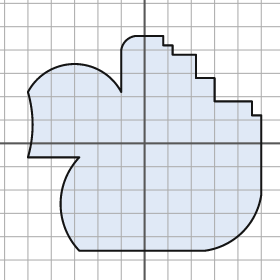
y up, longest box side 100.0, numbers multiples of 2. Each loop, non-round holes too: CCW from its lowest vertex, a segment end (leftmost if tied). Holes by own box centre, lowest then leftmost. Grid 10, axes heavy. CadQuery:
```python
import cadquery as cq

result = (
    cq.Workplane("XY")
    .moveTo(-28.0, -46.0)
    .lineTo(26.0, -46.0)
    .threePointArc((42.0, -38.0), (50.0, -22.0))
    .lineTo(50.0, 12.0)
    .lineTo(46.0, 12.0)
    .lineTo(46.0, 18.0)
    .lineTo(30.0, 18.0)
    .lineTo(30.0, 28.0)
    .lineTo(22.0, 28.0)
    .lineTo(22.0, 38.0)
    .lineTo(12.0, 38.0)
    .lineTo(12.0, 42.0)
    .lineTo(8.0, 42.0)
    .lineTo(8.0, 46.0)
    .lineTo(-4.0, 46.0)
    .threePointArc((-8.0, 44.0), (-10.0, 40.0))
    .lineTo(-10.0, 22.0)
    .threePointArc((-30.0, 34.0), (-50.0, 22.0))
    .threePointArc((-48.0, 8.0), (-50.0, -6.0))
    .lineTo(-28.0, -6.0)
    .threePointArc((-36.0, -26.0), (-28.0, -46.0))
    .close()
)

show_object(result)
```